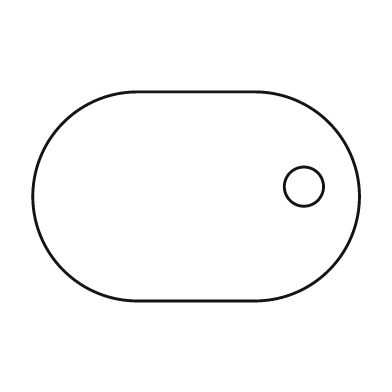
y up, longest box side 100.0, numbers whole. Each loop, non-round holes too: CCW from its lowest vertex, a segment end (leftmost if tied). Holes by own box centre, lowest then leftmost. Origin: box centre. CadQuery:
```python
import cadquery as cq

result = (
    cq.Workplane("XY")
    .moveTo(-18.0, -32.0)
    .lineTo(18.0, -32.0)
    .threePointArc((50.0, 0.0), (18.0, 32.0))
    .lineTo(-18.0, 32.0)
    .threePointArc((-50.0, 0.0), (-18.0, -32.0))
    .close()
    .moveTo(33.0, 3.0)
    .circle(6.0)
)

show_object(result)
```